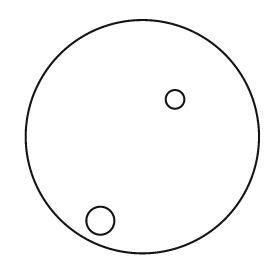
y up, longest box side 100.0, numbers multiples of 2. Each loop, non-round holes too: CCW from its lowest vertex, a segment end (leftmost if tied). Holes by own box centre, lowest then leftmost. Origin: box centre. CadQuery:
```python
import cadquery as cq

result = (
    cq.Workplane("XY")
    .moveTo(0.0, 0.0)
    .circle(50.0)
    .moveTo(-18.0, -36.0)
    .circle(6.0)
    .moveTo(14.0, 16.0)
    .circle(4.0)
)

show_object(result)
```